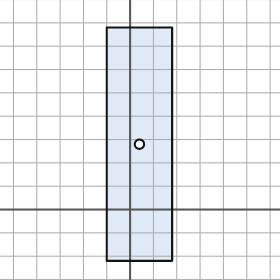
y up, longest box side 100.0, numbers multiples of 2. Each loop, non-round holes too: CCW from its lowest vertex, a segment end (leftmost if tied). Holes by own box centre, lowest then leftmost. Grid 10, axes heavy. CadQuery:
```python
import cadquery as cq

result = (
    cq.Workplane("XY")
    .moveTo(-10.0, -22.0)
    .lineTo(18.0, -22.0)
    .lineTo(18.0, 78.0)
    .lineTo(-10.0, 78.0)
    .close()
    .moveTo(4.0, 28.0)
    .circle(2.0)
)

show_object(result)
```